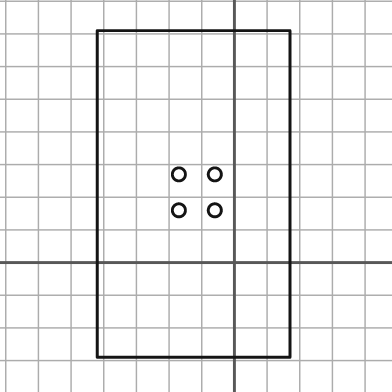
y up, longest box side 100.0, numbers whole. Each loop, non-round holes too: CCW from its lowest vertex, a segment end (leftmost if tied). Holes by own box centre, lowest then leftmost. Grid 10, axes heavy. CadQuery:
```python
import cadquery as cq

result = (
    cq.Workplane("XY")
    .moveTo(-42.0, -29.0)
    .lineTo(17.0, -29.0)
    .lineTo(17.0, 71.0)
    .lineTo(-42.0, 71.0)
    .close()
    .moveTo(-17.0, 16.0)
    .circle(2.0)
    .moveTo(-6.0, 16.0)
    .circle(2.0)
    .moveTo(-17.0, 27.0)
    .circle(2.0)
    .moveTo(-6.0, 27.0)
    .circle(2.0)
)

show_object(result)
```